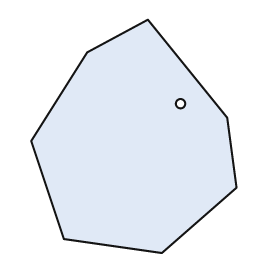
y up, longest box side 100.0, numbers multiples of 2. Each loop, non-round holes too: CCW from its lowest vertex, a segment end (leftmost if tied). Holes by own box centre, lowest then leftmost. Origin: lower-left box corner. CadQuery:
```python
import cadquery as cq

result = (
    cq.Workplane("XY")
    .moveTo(56.0, 0.0)
    .lineTo(88.0, 28.0)
    .lineTo(84.0, 58.0)
    .lineTo(50.0, 100.0)
    .lineTo(24.0, 86.0)
    .lineTo(0.0, 48.0)
    .lineTo(14.0, 6.0)
    .close()
    .moveTo(64.0, 64.0)
    .circle(2.0)
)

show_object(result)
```